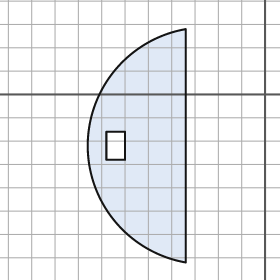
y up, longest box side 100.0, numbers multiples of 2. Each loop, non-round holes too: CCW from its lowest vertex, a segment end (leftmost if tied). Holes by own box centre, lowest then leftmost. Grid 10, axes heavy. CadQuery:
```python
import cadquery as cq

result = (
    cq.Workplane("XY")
    .moveTo(-34.0, -72.0)
    .lineTo(-34.0, 28.0)
    .threePointArc((-76.0, -22.0), (-34.0, -72.0))
    .close()
    .moveTo(-68.0, -28.0)
    .lineTo(-60.0, -28.0)
    .lineTo(-60.0, -16.0)
    .lineTo(-68.0, -16.0)
    .close()
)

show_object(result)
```